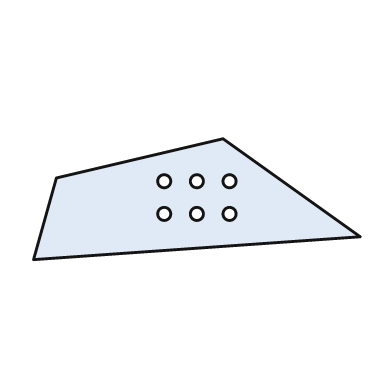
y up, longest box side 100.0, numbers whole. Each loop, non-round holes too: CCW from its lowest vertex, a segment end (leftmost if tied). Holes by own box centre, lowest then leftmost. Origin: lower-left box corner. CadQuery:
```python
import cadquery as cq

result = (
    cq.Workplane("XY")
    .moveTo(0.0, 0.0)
    .lineTo(100.0, 7.0)
    .lineTo(58.0, 37.0)
    .lineTo(7.0, 25.0)
    .close()
    .moveTo(40.0, 14.0)
    .circle(2.0)
    .moveTo(50.0, 14.0)
    .circle(2.0)
    .moveTo(60.0, 14.0)
    .circle(2.0)
    .moveTo(40.0, 24.0)
    .circle(2.0)
    .moveTo(50.0, 24.0)
    .circle(2.0)
    .moveTo(60.0, 24.0)
    .circle(2.0)
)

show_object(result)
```